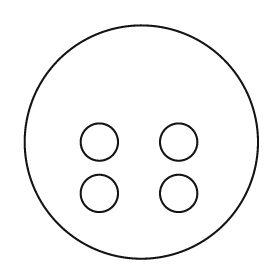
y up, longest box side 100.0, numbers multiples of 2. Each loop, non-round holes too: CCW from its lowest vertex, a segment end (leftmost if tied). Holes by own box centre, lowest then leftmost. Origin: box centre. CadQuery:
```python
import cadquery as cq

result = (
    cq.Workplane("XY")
    .moveTo(0.0, 0.0)
    .circle(50.0)
    .moveTo(-18.0, -22.0)
    .circle(8.0)
    .moveTo(16.0, -22.0)
    .circle(8.0)
    .moveTo(-18.0, 0.0)
    .circle(8.0)
    .moveTo(16.0, 0.0)
    .circle(8.0)
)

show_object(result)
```